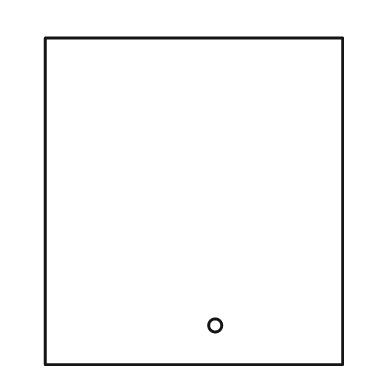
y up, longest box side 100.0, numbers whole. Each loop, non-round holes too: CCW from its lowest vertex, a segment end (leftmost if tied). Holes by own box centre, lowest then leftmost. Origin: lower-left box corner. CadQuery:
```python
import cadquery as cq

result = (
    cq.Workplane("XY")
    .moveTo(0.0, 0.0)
    .lineTo(91.0, 0.0)
    .lineTo(91.0, 100.0)
    .lineTo(0.0, 100.0)
    .close()
    .moveTo(52.0, 12.0)
    .circle(2.0)
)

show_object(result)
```